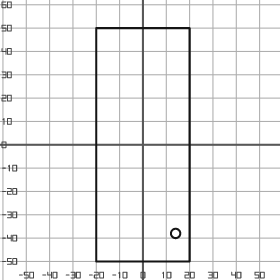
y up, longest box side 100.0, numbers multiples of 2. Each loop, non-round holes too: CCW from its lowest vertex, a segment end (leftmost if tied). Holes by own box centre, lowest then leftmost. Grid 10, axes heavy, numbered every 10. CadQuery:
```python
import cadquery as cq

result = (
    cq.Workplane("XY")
    .moveTo(-20.0, -50.0)
    .lineTo(20.0, -50.0)
    .lineTo(20.0, 50.0)
    .lineTo(-20.0, 50.0)
    .close()
    .moveTo(14.0, -38.0)
    .circle(2.0)
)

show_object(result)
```